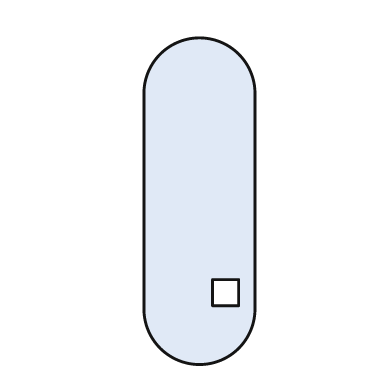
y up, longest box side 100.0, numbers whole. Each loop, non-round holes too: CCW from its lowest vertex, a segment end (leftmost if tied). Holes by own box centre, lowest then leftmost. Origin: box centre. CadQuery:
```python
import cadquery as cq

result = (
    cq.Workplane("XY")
    .moveTo(-17.0, -33.0)
    .threePointArc((0.0, -50.0), (17.0, -33.0))
    .lineTo(17.0, 33.0)
    .threePointArc((0.0, 50.0), (-17.0, 33.0))
    .close()
    .moveTo(4.0, -32.0)
    .lineTo(12.0, -32.0)
    .lineTo(12.0, -24.0)
    .lineTo(4.0, -24.0)
    .close()
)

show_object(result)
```